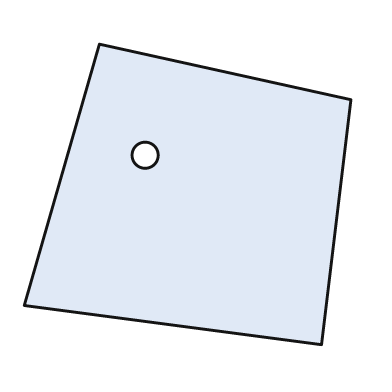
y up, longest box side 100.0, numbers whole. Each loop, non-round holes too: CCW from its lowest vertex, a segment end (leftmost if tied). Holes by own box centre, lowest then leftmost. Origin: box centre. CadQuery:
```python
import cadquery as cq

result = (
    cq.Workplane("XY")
    .moveTo(41.0, -46.0)
    .lineTo(50.0, 29.0)
    .lineTo(-27.0, 46.0)
    .lineTo(-50.0, -34.0)
    .close()
    .moveTo(-13.0, 12.0)
    .circle(4.0)
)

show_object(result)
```